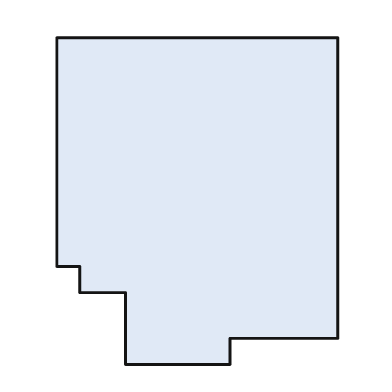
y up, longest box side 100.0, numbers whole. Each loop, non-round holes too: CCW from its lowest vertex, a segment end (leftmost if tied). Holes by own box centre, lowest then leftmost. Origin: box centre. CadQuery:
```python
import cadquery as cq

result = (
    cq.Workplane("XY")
    .moveTo(-22.0, -50.0)
    .lineTo(10.0, -50.0)
    .lineTo(10.0, -42.0)
    .lineTo(43.0, -42.0)
    .lineTo(43.0, 50.0)
    .lineTo(-43.0, 50.0)
    .lineTo(-43.0, -20.0)
    .lineTo(-36.0, -20.0)
    .lineTo(-36.0, -28.0)
    .lineTo(-22.0, -28.0)
    .close()
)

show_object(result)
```